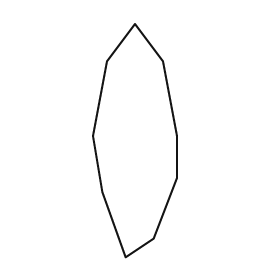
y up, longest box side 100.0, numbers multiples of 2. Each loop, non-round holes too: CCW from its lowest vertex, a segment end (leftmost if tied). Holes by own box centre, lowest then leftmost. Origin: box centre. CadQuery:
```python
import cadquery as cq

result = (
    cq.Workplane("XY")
    .moveTo(-4.0, -50.0)
    .lineTo(8.0, -42.0)
    .lineTo(18.0, -16.0)
    .lineTo(18.0, 2.0)
    .lineTo(12.0, 34.0)
    .lineTo(0.0, 50.0)
    .lineTo(-12.0, 34.0)
    .lineTo(-18.0, 2.0)
    .lineTo(-14.0, -22.0)
    .close()
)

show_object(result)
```